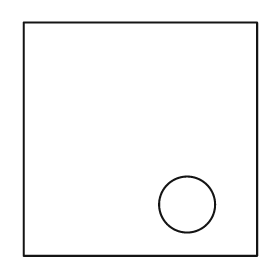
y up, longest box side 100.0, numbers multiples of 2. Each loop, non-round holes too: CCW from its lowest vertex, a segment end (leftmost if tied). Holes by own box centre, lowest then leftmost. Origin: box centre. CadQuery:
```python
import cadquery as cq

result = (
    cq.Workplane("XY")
    .moveTo(-50.0, -50.0)
    .lineTo(50.0, -50.0)
    .lineTo(50.0, 50.0)
    .lineTo(-50.0, 50.0)
    .close()
    .moveTo(20.0, -28.0)
    .circle(12.0)
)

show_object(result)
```